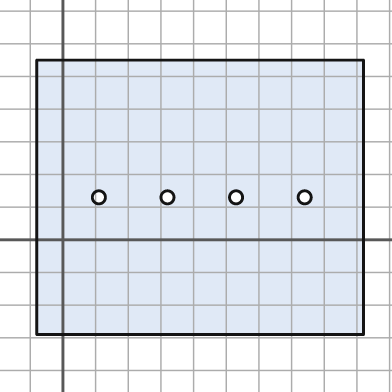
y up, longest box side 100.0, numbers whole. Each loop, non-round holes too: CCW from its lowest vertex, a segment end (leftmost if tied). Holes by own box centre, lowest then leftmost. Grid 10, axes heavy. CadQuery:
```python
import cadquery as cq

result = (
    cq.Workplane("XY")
    .moveTo(-8.0, -29.0)
    .lineTo(92.0, -29.0)
    .lineTo(92.0, 55.0)
    .lineTo(-8.0, 55.0)
    .close()
    .moveTo(11.0, 13.0)
    .circle(2.0)
    .moveTo(32.0, 13.0)
    .circle(2.0)
    .moveTo(53.0, 13.0)
    .circle(2.0)
    .moveTo(74.0, 13.0)
    .circle(2.0)
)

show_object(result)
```